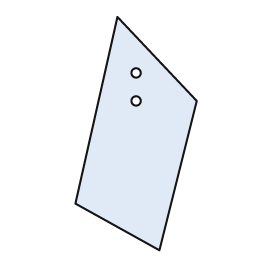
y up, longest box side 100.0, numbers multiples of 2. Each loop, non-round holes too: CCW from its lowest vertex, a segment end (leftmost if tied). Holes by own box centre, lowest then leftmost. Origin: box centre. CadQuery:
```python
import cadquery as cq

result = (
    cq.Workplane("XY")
    .moveTo(10.0, -50.0)
    .lineTo(26.0, 14.0)
    .lineTo(-8.0, 50.0)
    .lineTo(-26.0, -30.0)
    .close()
    .moveTo(0.0, 14.0)
    .circle(2.0)
    .moveTo(0.0, 26.0)
    .circle(2.0)
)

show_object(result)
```